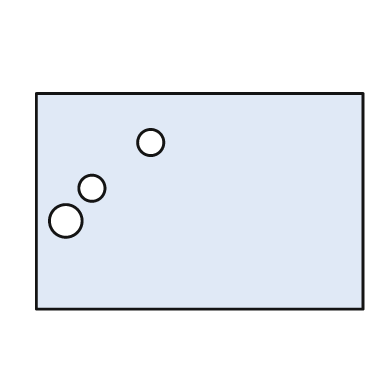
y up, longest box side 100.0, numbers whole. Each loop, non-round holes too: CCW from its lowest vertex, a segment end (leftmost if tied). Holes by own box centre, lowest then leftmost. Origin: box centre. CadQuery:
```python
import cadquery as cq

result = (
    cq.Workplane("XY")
    .moveTo(-50.0, -33.0)
    .lineTo(50.0, -33.0)
    .lineTo(50.0, 33.0)
    .lineTo(-50.0, 33.0)
    .close()
    .moveTo(-41.0, -6.0)
    .circle(5.0)
    .moveTo(-33.0, 4.0)
    .circle(4.0)
    .moveTo(-15.0, 18.0)
    .circle(4.0)
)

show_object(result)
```